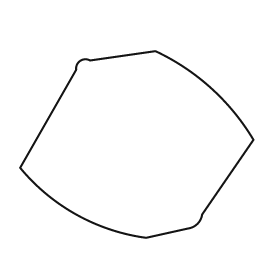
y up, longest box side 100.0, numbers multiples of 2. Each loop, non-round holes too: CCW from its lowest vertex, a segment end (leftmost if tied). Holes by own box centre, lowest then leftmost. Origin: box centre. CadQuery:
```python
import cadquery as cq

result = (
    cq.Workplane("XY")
    .moveTo(4.0, -40.0)
    .lineTo(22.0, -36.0)
    .threePointArc((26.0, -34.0), (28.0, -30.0))
    .lineTo(50.0, 2.0)
    .threePointArc((32.0, 24.0), (8.0, 40.0))
    .lineTo(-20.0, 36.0)
    .threePointArc((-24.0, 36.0), (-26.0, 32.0))
    .lineTo(-50.0, -10.0)
    .threePointArc((-26.0, -30.0), (4.0, -40.0))
    .close()
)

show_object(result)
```